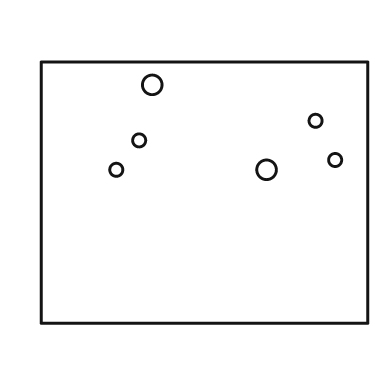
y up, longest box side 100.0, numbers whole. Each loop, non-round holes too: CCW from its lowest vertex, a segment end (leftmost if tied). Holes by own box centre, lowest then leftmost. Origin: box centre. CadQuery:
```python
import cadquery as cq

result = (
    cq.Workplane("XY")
    .moveTo(-50.0, -40.0)
    .lineTo(50.0, -40.0)
    .lineTo(50.0, 40.0)
    .lineTo(-50.0, 40.0)
    .close()
    .moveTo(-27.0, 7.0)
    .circle(2.0)
    .moveTo(19.0, 7.0)
    .circle(3.0)
    .moveTo(40.0, 10.0)
    .circle(2.0)
    .moveTo(-20.0, 16.0)
    .circle(2.0)
    .moveTo(34.0, 22.0)
    .circle(2.0)
    .moveTo(-16.0, 33.0)
    .circle(3.0)
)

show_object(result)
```